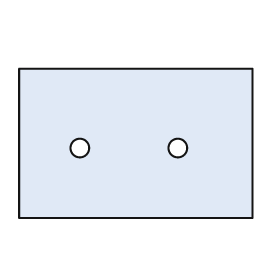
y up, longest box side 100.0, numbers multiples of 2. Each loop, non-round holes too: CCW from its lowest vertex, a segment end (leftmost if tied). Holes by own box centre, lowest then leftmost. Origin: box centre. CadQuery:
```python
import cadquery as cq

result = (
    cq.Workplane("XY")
    .moveTo(-50.0, -32.0)
    .lineTo(50.0, -32.0)
    .lineTo(50.0, 32.0)
    .lineTo(-50.0, 32.0)
    .close()
    .moveTo(-24.0, -2.0)
    .circle(4.0)
    .moveTo(18.0, -2.0)
    .circle(4.0)
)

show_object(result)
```